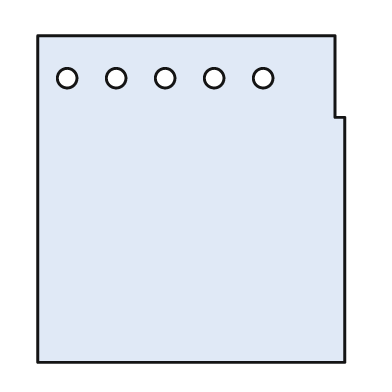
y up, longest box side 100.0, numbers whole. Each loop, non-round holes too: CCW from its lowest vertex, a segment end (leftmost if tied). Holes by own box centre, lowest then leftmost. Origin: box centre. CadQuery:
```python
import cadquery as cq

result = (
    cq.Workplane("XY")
    .moveTo(-47.0, -50.0)
    .lineTo(47.0, -50.0)
    .lineTo(47.0, 25.0)
    .lineTo(44.0, 25.0)
    .lineTo(44.0, 50.0)
    .lineTo(-47.0, 50.0)
    .close()
    .moveTo(-38.0, 37.0)
    .circle(3.0)
    .moveTo(-23.0, 37.0)
    .circle(3.0)
    .moveTo(-8.0, 37.0)
    .circle(3.0)
    .moveTo(7.0, 37.0)
    .circle(3.0)
    .moveTo(22.0, 37.0)
    .circle(3.0)
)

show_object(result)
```